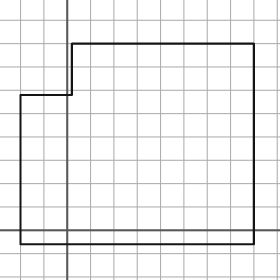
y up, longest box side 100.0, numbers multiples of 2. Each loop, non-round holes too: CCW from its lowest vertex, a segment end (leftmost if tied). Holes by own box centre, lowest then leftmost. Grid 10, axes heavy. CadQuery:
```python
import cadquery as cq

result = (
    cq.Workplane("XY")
    .moveTo(-20.0, -6.0)
    .lineTo(80.0, -6.0)
    .lineTo(80.0, 80.0)
    .lineTo(2.0, 80.0)
    .lineTo(2.0, 58.0)
    .lineTo(-20.0, 58.0)
    .close()
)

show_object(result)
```